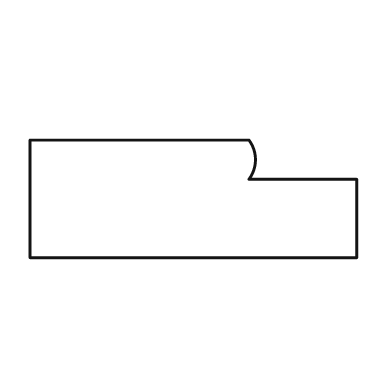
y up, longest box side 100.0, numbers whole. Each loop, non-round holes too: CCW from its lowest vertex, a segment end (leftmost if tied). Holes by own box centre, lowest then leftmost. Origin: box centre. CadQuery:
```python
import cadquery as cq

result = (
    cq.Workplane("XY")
    .moveTo(-50.0, -18.0)
    .lineTo(50.0, -18.0)
    .lineTo(50.0, 6.0)
    .lineTo(17.0, 6.0)
    .threePointArc((19.0, 12.0), (17.0, 18.0))
    .lineTo(-50.0, 18.0)
    .close()
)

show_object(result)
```